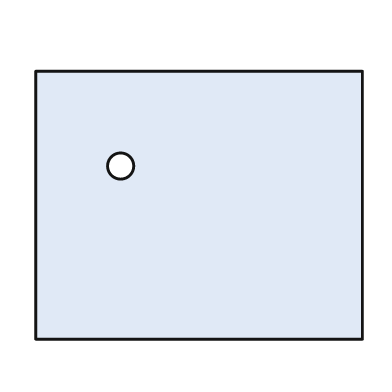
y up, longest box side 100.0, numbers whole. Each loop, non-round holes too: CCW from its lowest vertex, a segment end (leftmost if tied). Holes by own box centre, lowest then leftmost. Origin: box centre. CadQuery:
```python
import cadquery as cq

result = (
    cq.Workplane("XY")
    .moveTo(-50.0, -41.0)
    .lineTo(50.0, -41.0)
    .lineTo(50.0, 41.0)
    .lineTo(-50.0, 41.0)
    .close()
    .moveTo(-24.0, 12.0)
    .circle(4.0)
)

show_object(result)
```